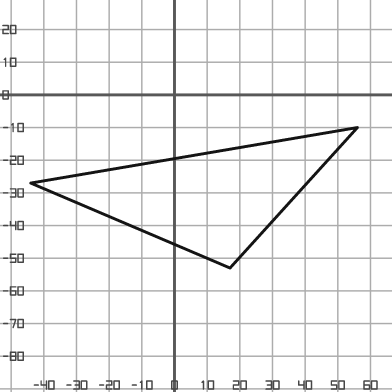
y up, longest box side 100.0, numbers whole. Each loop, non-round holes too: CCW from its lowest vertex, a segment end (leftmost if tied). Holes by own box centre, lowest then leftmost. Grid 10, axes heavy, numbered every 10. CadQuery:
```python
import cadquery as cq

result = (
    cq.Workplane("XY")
    .moveTo(17.0, -53.0)
    .lineTo(56.0, -10.0)
    .lineTo(-44.0, -27.0)
    .close()
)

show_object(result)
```